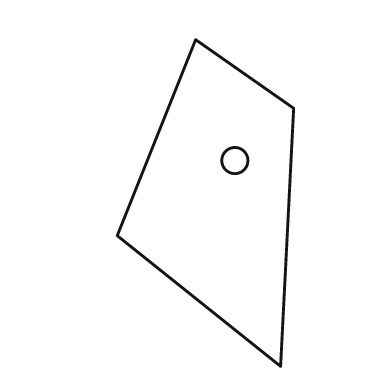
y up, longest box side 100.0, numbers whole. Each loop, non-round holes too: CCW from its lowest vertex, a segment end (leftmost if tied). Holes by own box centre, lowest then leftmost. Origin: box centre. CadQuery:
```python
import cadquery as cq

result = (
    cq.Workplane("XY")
    .moveTo(23.0, -50.0)
    .lineTo(27.0, 29.0)
    .lineTo(-3.0, 50.0)
    .lineTo(-27.0, -10.0)
    .close()
    .moveTo(9.0, 13.0)
    .circle(4.0)
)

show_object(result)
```